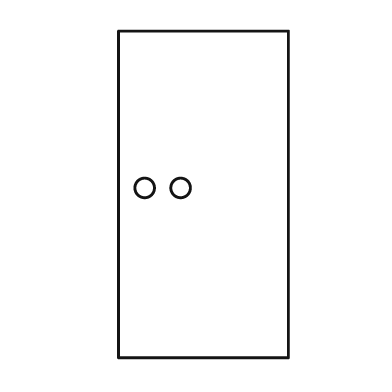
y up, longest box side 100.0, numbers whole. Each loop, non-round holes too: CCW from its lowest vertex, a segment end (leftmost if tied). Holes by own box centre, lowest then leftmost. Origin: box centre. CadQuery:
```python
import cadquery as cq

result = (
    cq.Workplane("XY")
    .moveTo(-26.0, -50.0)
    .lineTo(26.0, -50.0)
    .lineTo(26.0, 50.0)
    .lineTo(-26.0, 50.0)
    .close()
    .moveTo(-18.0, 2.0)
    .circle(3.0)
    .moveTo(-7.0, 2.0)
    .circle(3.0)
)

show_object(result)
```